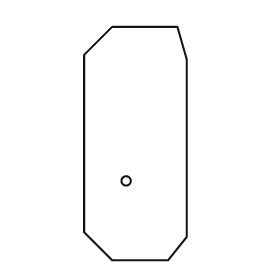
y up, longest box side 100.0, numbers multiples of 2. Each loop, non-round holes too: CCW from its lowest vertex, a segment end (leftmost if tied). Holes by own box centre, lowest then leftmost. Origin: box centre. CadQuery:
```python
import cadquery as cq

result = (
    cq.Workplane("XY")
    .moveTo(-10.0, -50.0)
    .lineTo(14.0, -50.0)
    .lineTo(22.0, -40.0)
    .lineTo(22.0, 36.0)
    .lineTo(18.0, 50.0)
    .lineTo(-10.0, 50.0)
    .lineTo(-22.0, 38.0)
    .lineTo(-22.0, -38.0)
    .close()
    .moveTo(-4.0, -16.0)
    .circle(2.0)
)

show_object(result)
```